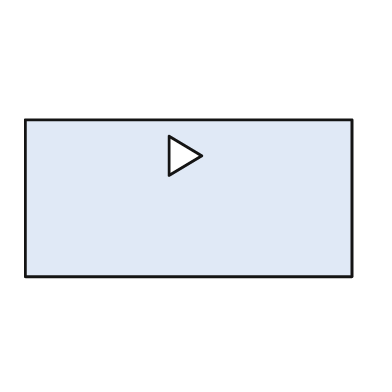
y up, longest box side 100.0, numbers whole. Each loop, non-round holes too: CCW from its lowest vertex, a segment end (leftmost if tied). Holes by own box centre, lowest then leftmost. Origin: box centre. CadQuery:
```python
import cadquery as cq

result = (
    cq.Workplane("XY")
    .moveTo(-50.0, -24.0)
    .lineTo(50.0, -24.0)
    .lineTo(50.0, 24.0)
    .lineTo(-50.0, 24.0)
    .close()
    .moveTo(-6.0, 7.0)
    .lineTo(4.0, 13.0)
    .lineTo(-6.0, 19.0)
    .close()
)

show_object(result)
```